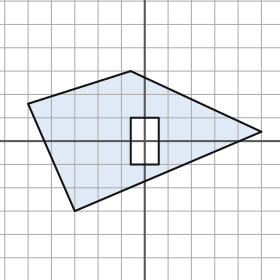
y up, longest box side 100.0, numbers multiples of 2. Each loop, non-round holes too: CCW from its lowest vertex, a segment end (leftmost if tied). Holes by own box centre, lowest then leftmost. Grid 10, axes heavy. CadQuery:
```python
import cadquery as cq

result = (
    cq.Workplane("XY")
    .moveTo(-30.0, -30.0)
    .lineTo(50.0, 4.0)
    .lineTo(-6.0, 30.0)
    .lineTo(-50.0, 16.0)
    .close()
    .moveTo(-6.0, -10.0)
    .lineTo(6.0, -10.0)
    .lineTo(6.0, 10.0)
    .lineTo(-6.0, 10.0)
    .close()
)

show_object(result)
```